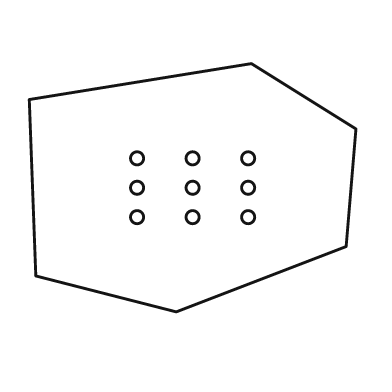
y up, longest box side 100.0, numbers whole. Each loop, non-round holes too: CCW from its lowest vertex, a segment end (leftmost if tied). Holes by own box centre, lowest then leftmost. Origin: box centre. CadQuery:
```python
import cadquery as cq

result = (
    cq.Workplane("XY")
    .moveTo(-5.0, -38.0)
    .lineTo(47.0, -18.0)
    .lineTo(50.0, 18.0)
    .lineTo(18.0, 38.0)
    .lineTo(-50.0, 27.0)
    .lineTo(-48.0, -27.0)
    .close()
    .moveTo(-17.0, -9.0)
    .circle(2.0)
    .moveTo(0.0, -9.0)
    .circle(2.0)
    .moveTo(17.0, -9.0)
    .circle(2.0)
    .moveTo(-17.0, 0.0)
    .circle(2.0)
    .moveTo(0.0, 0.0)
    .circle(2.0)
    .moveTo(17.0, 0.0)
    .circle(2.0)
    .moveTo(-17.0, 9.0)
    .circle(2.0)
    .moveTo(0.0, 9.0)
    .circle(2.0)
    .moveTo(17.0, 9.0)
    .circle(2.0)
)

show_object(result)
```